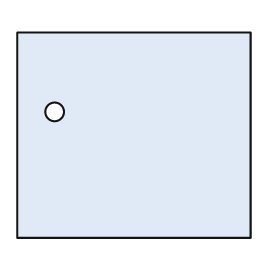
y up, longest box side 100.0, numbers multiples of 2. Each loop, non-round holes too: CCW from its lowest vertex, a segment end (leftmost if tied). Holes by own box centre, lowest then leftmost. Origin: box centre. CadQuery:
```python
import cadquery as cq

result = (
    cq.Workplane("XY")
    .moveTo(-50.0, -44.0)
    .lineTo(50.0, -44.0)
    .lineTo(50.0, 44.0)
    .lineTo(-50.0, 44.0)
    .close()
    .moveTo(-34.0, 10.0)
    .circle(4.0)
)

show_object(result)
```